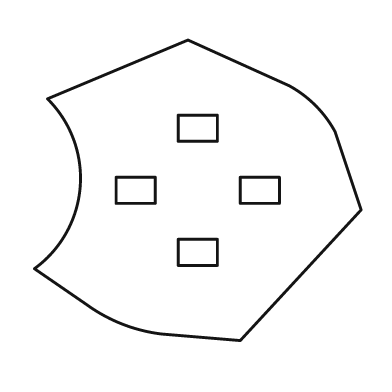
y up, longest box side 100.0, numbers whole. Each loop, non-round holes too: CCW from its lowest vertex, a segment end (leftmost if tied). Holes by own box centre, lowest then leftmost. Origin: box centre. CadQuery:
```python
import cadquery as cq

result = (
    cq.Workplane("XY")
    .moveTo(13.0, -46.0)
    .lineTo(50.0, -6.0)
    .lineTo(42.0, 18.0)
    .threePointArc((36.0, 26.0), (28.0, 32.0))
    .lineTo(-3.0, 46.0)
    .lineTo(-46.0, 28.0)
    .threePointArc((-36.0, 1.0), (-50.0, -24.0))
    .lineTo(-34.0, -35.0)
    .threePointArc((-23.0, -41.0), (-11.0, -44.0))
    .close()
    .moveTo(-6.0, -23.0)
    .lineTo(6.0, -23.0)
    .lineTo(6.0, -15.0)
    .lineTo(-6.0, -15.0)
    .close()
    .moveTo(-25.0, -4.0)
    .lineTo(-13.0, -4.0)
    .lineTo(-13.0, 4.0)
    .lineTo(-25.0, 4.0)
    .close()
    .moveTo(13.0, -4.0)
    .lineTo(25.0, -4.0)
    .lineTo(25.0, 4.0)
    .lineTo(13.0, 4.0)
    .close()
    .moveTo(-6.0, 15.0)
    .lineTo(6.0, 15.0)
    .lineTo(6.0, 23.0)
    .lineTo(-6.0, 23.0)
    .close()
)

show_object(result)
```